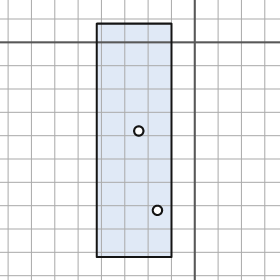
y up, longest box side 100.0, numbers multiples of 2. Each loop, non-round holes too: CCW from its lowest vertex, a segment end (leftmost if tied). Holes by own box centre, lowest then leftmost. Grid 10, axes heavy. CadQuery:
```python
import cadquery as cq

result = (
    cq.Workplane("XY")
    .moveTo(-42.0, -92.0)
    .lineTo(-10.0, -92.0)
    .lineTo(-10.0, 8.0)
    .lineTo(-42.0, 8.0)
    .close()
    .moveTo(-16.0, -72.0)
    .circle(2.0)
    .moveTo(-24.0, -38.0)
    .circle(2.0)
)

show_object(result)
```